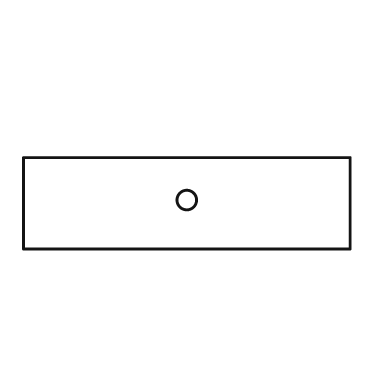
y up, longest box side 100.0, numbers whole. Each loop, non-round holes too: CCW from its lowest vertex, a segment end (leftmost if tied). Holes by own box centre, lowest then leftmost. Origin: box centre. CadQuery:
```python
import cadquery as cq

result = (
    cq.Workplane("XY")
    .moveTo(-50.0, -14.0)
    .lineTo(50.0, -14.0)
    .lineTo(50.0, 14.0)
    .lineTo(-50.0, 14.0)
    .close()
    .moveTo(0.0, 1.0)
    .circle(3.0)
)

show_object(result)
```